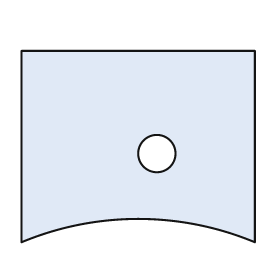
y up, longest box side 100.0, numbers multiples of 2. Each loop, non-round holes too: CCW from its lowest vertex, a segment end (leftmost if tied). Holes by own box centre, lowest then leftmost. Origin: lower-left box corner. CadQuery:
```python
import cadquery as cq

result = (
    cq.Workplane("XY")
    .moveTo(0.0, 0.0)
    .threePointArc((50.0, 10.0), (100.0, 0.0))
    .lineTo(100.0, 82.0)
    .lineTo(0.0, 82.0)
    .close()
    .moveTo(58.0, 38.0)
    .circle(8.0)
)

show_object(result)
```